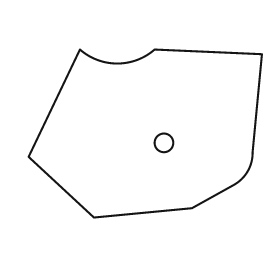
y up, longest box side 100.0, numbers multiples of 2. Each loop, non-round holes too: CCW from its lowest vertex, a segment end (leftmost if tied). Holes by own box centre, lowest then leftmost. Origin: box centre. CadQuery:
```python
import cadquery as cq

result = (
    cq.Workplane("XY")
    .moveTo(-22.0, -36.0)
    .lineTo(20.0, -32.0)
    .lineTo(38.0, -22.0)
    .threePointArc((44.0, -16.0), (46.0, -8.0))
    .lineTo(50.0, 34.0)
    .lineTo(4.0, 36.0)
    .threePointArc((-12.0, 30.0), (-28.0, 36.0))
    .lineTo(-50.0, -10.0)
    .close()
    .moveTo(8.0, -4.0)
    .circle(4.0)
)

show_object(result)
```